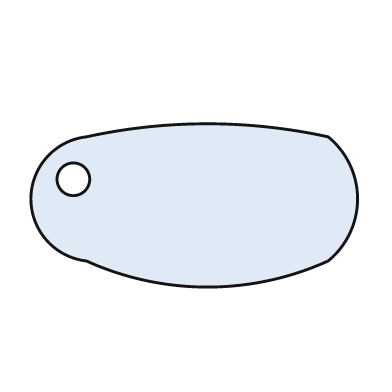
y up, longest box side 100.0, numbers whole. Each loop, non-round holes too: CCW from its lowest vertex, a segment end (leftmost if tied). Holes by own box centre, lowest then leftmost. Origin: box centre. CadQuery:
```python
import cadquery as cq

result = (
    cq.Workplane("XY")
    .moveTo(-33.0, -17.0)
    .threePointArc((4.0, -25.0), (41.0, -17.0))
    .threePointArc((50.0, 2.0), (41.0, 21.0))
    .threePointArc((4.0, 25.0), (-33.0, 21.0))
    .threePointArc((-50.0, 2.0), (-33.0, -17.0))
    .close()
    .moveTo(-37.0, 8.0)
    .circle(5.0)
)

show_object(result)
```